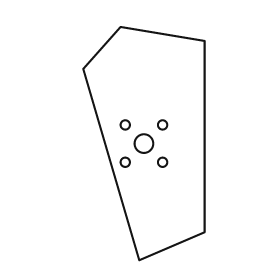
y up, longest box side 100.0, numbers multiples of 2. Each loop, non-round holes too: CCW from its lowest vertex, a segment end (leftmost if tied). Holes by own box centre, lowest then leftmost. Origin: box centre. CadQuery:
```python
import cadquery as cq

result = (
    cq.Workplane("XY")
    .moveTo(-2.0, -50.0)
    .lineTo(26.0, -38.0)
    .lineTo(26.0, 44.0)
    .lineTo(-10.0, 50.0)
    .lineTo(-26.0, 32.0)
    .close()
    .moveTo(-8.0, -8.0)
    .circle(2.0)
    .moveTo(8.0, -8.0)
    .circle(2.0)
    .moveTo(0.0, 0.0)
    .circle(4.0)
    .moveTo(-8.0, 8.0)
    .circle(2.0)
    .moveTo(8.0, 8.0)
    .circle(2.0)
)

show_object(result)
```